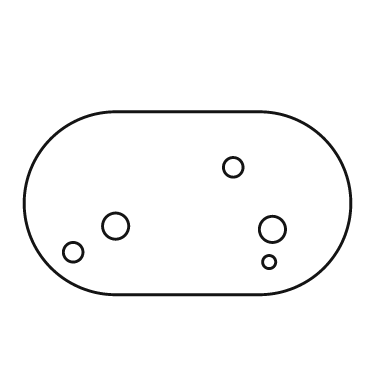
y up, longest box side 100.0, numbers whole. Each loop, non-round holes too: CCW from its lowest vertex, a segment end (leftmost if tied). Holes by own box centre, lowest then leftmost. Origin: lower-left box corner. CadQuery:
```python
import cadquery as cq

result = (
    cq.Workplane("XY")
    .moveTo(28.0, 0.0)
    .lineTo(72.0, 0.0)
    .threePointArc((100.0, 28.0), (72.0, 56.0))
    .lineTo(28.0, 56.0)
    .threePointArc((0.0, 28.0), (28.0, 0.0))
    .close()
    .moveTo(75.0, 10.0)
    .circle(2.0)
    .moveTo(15.0, 13.0)
    .circle(3.0)
    .moveTo(76.0, 20.0)
    .circle(4.0)
    .moveTo(28.0, 21.0)
    .circle(4.0)
    .moveTo(64.0, 39.0)
    .circle(3.0)
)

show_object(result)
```